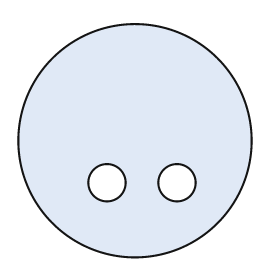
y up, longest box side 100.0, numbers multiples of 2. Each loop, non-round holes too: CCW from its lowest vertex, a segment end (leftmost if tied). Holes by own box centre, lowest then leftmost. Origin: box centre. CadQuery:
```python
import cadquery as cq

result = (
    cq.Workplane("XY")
    .moveTo(0.0, 0.0)
    .circle(50.0)
    .moveTo(-12.0, -18.0)
    .circle(8.0)
    .moveTo(18.0, -18.0)
    .circle(8.0)
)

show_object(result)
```